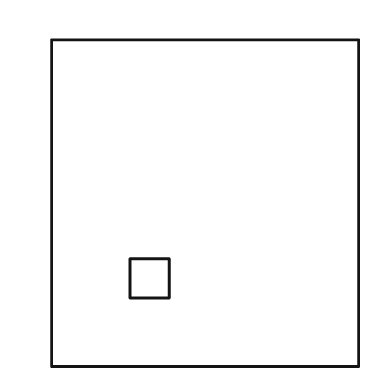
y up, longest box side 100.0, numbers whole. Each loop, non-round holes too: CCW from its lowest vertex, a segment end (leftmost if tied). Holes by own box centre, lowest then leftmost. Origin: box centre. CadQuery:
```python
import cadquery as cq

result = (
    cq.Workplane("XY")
    .moveTo(-47.0, -50.0)
    .lineTo(47.0, -50.0)
    .lineTo(47.0, 50.0)
    .lineTo(-47.0, 50.0)
    .close()
    .moveTo(-23.0, -29.0)
    .lineTo(-11.0, -29.0)
    .lineTo(-11.0, -17.0)
    .lineTo(-23.0, -17.0)
    .close()
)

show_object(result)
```